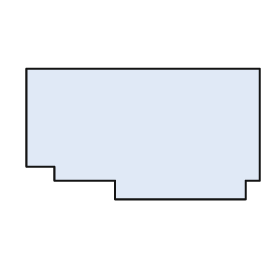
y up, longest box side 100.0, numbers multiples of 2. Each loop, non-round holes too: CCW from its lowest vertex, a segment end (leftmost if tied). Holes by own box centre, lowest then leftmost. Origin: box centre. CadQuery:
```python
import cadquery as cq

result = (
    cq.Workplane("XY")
    .moveTo(-12.0, -28.0)
    .lineTo(44.0, -28.0)
    .lineTo(44.0, -20.0)
    .lineTo(50.0, -20.0)
    .lineTo(50.0, 28.0)
    .lineTo(-50.0, 28.0)
    .lineTo(-50.0, -14.0)
    .lineTo(-38.0, -14.0)
    .lineTo(-38.0, -20.0)
    .lineTo(-12.0, -20.0)
    .close()
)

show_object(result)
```